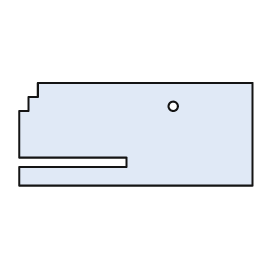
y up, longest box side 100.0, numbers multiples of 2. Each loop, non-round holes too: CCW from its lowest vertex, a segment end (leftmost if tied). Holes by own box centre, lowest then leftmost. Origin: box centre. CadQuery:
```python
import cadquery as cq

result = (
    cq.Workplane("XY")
    .moveTo(-50.0, -22.0)
    .lineTo(50.0, -22.0)
    .lineTo(50.0, 22.0)
    .lineTo(-42.0, 22.0)
    .lineTo(-42.0, 16.0)
    .lineTo(-46.0, 16.0)
    .lineTo(-46.0, 10.0)
    .lineTo(-50.0, 10.0)
    .lineTo(-50.0, -10.0)
    .lineTo(-4.0, -10.0)
    .lineTo(-4.0, -14.0)
    .lineTo(-50.0, -14.0)
    .close()
    .moveTo(16.0, 12.0)
    .circle(2.0)
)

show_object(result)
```